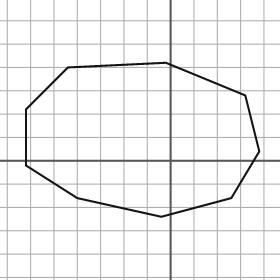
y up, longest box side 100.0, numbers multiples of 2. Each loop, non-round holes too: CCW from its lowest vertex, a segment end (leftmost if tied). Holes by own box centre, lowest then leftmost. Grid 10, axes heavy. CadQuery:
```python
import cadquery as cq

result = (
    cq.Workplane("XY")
    .moveTo(-4.0, -24.0)
    .lineTo(26.0, -16.0)
    .lineTo(38.0, 4.0)
    .lineTo(32.0, 28.0)
    .lineTo(-2.0, 42.0)
    .lineTo(-44.0, 40.0)
    .lineTo(-62.0, 22.0)
    .lineTo(-62.0, -2.0)
    .lineTo(-40.0, -16.0)
    .close()
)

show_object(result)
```